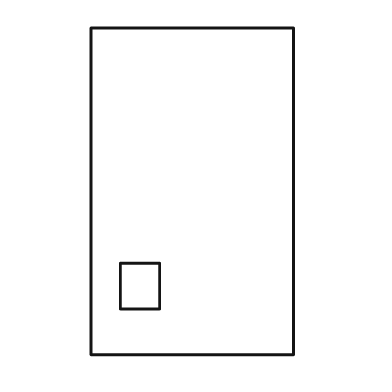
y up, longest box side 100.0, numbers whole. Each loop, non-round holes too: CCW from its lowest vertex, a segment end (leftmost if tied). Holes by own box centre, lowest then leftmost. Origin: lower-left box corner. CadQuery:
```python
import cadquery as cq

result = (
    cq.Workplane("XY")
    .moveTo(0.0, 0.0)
    .lineTo(62.0, 0.0)
    .lineTo(62.0, 100.0)
    .lineTo(0.0, 100.0)
    .close()
    .moveTo(9.0, 14.0)
    .lineTo(21.0, 14.0)
    .lineTo(21.0, 28.0)
    .lineTo(9.0, 28.0)
    .close()
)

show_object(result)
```